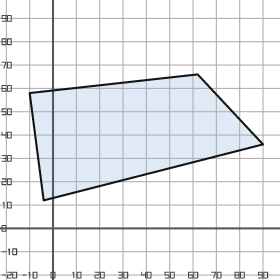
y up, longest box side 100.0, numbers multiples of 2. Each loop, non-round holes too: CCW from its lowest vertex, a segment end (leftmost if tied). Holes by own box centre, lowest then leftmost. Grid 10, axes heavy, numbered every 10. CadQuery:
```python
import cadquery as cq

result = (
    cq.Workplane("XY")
    .moveTo(-4.0, 12.0)
    .lineTo(90.0, 36.0)
    .lineTo(62.0, 66.0)
    .lineTo(-10.0, 58.0)
    .close()
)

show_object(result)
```